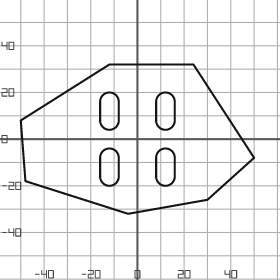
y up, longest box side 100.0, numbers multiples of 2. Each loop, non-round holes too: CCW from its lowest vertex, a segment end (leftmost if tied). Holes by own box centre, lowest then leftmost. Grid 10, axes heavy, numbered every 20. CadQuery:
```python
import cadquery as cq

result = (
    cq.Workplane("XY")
    .moveTo(-4.0, -32.0)
    .lineTo(30.0, -26.0)
    .lineTo(50.0, -8.0)
    .lineTo(24.0, 32.0)
    .lineTo(-12.0, 32.0)
    .lineTo(-50.0, 8.0)
    .lineTo(-48.0, -18.0)
    .close()
    .moveTo(-16.0, -16.0)
    .threePointArc((-12.0, -20.0), (-8.0, -16.0))
    .lineTo(-8.0, -8.0)
    .threePointArc((-12.0, -4.0), (-16.0, -8.0))
    .close()
    .moveTo(8.0, -16.0)
    .threePointArc((12.0, -20.0), (16.0, -16.0))
    .lineTo(16.0, -8.0)
    .threePointArc((12.0, -4.0), (8.0, -8.0))
    .close()
    .moveTo(-16.0, 8.0)
    .threePointArc((-12.0, 4.0), (-8.0, 8.0))
    .lineTo(-8.0, 16.0)
    .threePointArc((-12.0, 20.0), (-16.0, 16.0))
    .close()
    .moveTo(8.0, 8.0)
    .threePointArc((12.0, 4.0), (16.0, 8.0))
    .lineTo(16.0, 16.0)
    .threePointArc((12.0, 20.0), (8.0, 16.0))
    .close()
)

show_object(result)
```